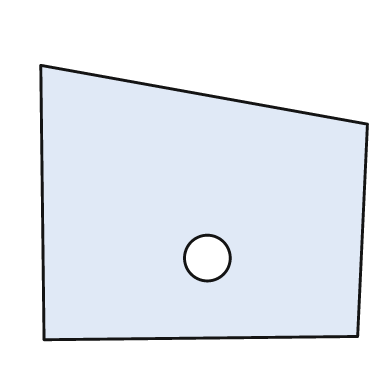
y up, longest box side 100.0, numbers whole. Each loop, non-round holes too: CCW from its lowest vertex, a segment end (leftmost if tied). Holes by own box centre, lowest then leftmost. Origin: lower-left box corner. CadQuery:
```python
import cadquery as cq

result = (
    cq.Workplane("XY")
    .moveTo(1.0, 0.0)
    .lineTo(97.0, 1.0)
    .lineTo(100.0, 66.0)
    .lineTo(0.0, 84.0)
    .close()
    .moveTo(51.0, 25.0)
    .circle(7.0)
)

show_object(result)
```